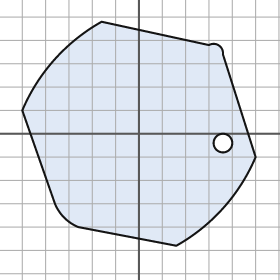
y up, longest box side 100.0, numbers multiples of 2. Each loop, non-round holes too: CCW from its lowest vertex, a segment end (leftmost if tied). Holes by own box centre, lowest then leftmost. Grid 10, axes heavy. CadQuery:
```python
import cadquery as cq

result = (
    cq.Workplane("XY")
    .moveTo(16.0, -48.0)
    .threePointArc((36.0, -32.0), (50.0, -10.0))
    .lineTo(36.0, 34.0)
    .threePointArc((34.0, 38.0), (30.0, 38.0))
    .lineTo(-16.0, 48.0)
    .threePointArc((-36.0, 32.0), (-50.0, 10.0))
    .lineTo(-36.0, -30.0)
    .threePointArc((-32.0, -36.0), (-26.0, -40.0))
    .close()
    .moveTo(36.0, -4.0)
    .circle(4.0)
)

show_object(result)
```